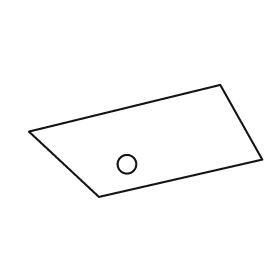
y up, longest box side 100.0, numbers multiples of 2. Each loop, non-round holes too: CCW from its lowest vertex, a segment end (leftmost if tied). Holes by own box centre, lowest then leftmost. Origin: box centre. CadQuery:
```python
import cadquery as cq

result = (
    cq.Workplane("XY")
    .moveTo(-20.0, -24.0)
    .lineTo(50.0, -8.0)
    .lineTo(32.0, 24.0)
    .lineTo(-50.0, 4.0)
    .close()
    .moveTo(-8.0, -10.0)
    .circle(4.0)
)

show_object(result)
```